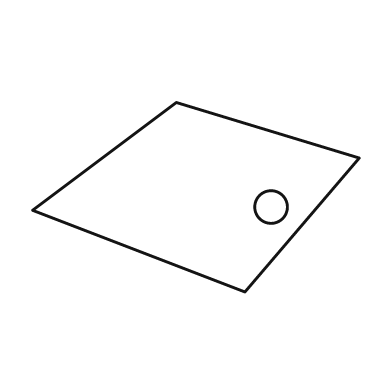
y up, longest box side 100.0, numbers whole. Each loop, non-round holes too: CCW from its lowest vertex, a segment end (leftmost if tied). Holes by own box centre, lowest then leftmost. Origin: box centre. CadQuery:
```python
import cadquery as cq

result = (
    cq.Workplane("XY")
    .moveTo(15.0, -29.0)
    .lineTo(50.0, 12.0)
    .lineTo(-6.0, 29.0)
    .lineTo(-50.0, -4.0)
    .close()
    .moveTo(23.0, -3.0)
    .circle(5.0)
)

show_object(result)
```